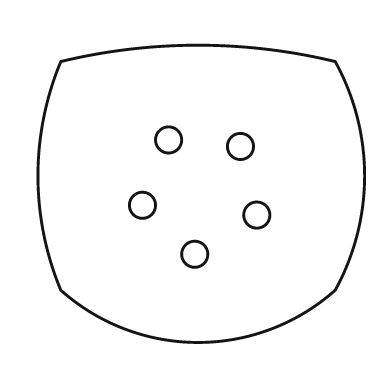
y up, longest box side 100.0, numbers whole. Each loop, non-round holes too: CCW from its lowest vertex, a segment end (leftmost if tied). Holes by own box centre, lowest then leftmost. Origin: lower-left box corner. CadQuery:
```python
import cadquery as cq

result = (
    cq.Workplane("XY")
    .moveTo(7.0, 16.0)
    .threePointArc((49.0, 0.0), (91.0, 16.0))
    .threePointArc((100.0, 51.0), (91.0, 86.0))
    .threePointArc((49.0, 91.0), (7.0, 86.0))
    .threePointArc((0.0, 51.0), (7.0, 16.0))
    .close()
    .moveTo(48.0, 27.0)
    .circle(4.0)
    .moveTo(67.0, 39.0)
    .circle(4.0)
    .moveTo(32.0, 42.0)
    .circle(4.0)
    .moveTo(62.0, 60.0)
    .circle(4.0)
    .moveTo(40.0, 62.0)
    .circle(4.0)
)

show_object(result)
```